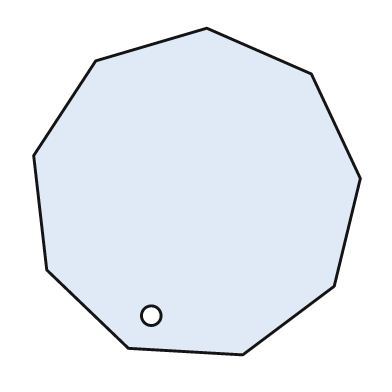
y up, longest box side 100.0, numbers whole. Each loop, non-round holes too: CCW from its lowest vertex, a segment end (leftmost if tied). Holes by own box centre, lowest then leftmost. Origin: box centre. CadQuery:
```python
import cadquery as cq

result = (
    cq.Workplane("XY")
    .moveTo(14.0, -50.0)
    .lineTo(42.0, -29.0)
    .lineTo(50.0, 4.0)
    .lineTo(35.0, 36.0)
    .lineTo(3.0, 50.0)
    .lineTo(-31.0, 40.0)
    .lineTo(-50.0, 11.0)
    .lineTo(-46.0, -24.0)
    .lineTo(-21.0, -48.0)
    .close()
    .moveTo(-14.0, -38.0)
    .circle(3.0)
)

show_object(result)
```